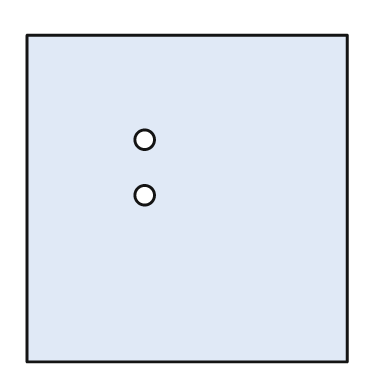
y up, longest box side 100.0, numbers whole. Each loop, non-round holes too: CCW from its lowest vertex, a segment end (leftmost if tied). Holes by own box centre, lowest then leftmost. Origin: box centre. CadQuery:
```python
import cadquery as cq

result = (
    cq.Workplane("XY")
    .moveTo(-49.0, -50.0)
    .lineTo(49.0, -50.0)
    .lineTo(49.0, 50.0)
    .lineTo(-49.0, 50.0)
    .close()
    .moveTo(-13.0, 1.0)
    .circle(3.0)
    .moveTo(-13.0, 18.0)
    .circle(3.0)
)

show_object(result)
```